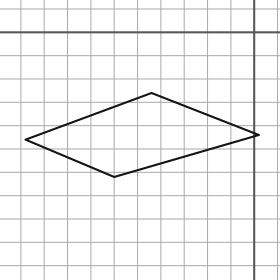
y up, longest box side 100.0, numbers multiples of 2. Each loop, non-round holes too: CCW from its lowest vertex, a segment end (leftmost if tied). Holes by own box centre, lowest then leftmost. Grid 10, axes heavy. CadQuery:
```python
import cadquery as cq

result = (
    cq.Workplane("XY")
    .moveTo(-60.0, -62.0)
    .lineTo(2.0, -44.0)
    .lineTo(-44.0, -26.0)
    .lineTo(-98.0, -46.0)
    .close()
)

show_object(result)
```